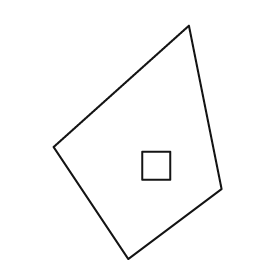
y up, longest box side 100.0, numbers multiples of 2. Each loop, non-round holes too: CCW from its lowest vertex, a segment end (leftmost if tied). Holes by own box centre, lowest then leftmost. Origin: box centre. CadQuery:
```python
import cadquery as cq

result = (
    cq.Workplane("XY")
    .moveTo(-4.0, -50.0)
    .lineTo(36.0, -20.0)
    .lineTo(22.0, 50.0)
    .lineTo(-36.0, -2.0)
    .close()
    .moveTo(2.0, -16.0)
    .lineTo(14.0, -16.0)
    .lineTo(14.0, -4.0)
    .lineTo(2.0, -4.0)
    .close()
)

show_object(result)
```